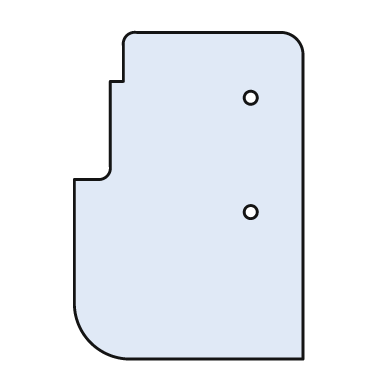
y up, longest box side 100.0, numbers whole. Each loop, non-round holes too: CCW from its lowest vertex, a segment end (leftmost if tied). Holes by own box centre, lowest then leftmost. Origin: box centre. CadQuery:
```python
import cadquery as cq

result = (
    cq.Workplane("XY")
    .moveTo(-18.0, -50.0)
    .lineTo(35.0, -50.0)
    .lineTo(35.0, 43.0)
    .threePointArc((33.0, 48.0), (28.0, 50.0))
    .lineTo(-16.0, 50.0)
    .threePointArc((-19.0, 49.0), (-20.0, 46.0))
    .lineTo(-20.0, 35.0)
    .lineTo(-24.0, 35.0)
    .lineTo(-24.0, 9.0)
    .threePointArc((-25.0, 6.0), (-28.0, 5.0))
    .lineTo(-35.0, 5.0)
    .lineTo(-35.0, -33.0)
    .threePointArc((-30.0, -45.0), (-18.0, -50.0))
    .close()
    .moveTo(19.0, -5.0)
    .circle(2.0)
    .moveTo(19.0, 30.0)
    .circle(2.0)
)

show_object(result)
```